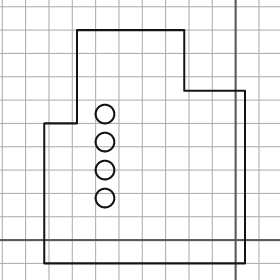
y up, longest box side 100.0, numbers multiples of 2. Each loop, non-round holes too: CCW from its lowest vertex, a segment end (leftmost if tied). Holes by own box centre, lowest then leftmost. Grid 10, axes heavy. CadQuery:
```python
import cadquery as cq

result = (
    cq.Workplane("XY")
    .moveTo(-82.0, -10.0)
    .lineTo(4.0, -10.0)
    .lineTo(4.0, 64.0)
    .lineTo(-22.0, 64.0)
    .lineTo(-22.0, 90.0)
    .lineTo(-68.0, 90.0)
    .lineTo(-68.0, 50.0)
    .lineTo(-82.0, 50.0)
    .close()
    .moveTo(-56.0, 18.0)
    .circle(4.0)
    .moveTo(-56.0, 30.0)
    .circle(4.0)
    .moveTo(-56.0, 42.0)
    .circle(4.0)
    .moveTo(-56.0, 54.0)
    .circle(4.0)
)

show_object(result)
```